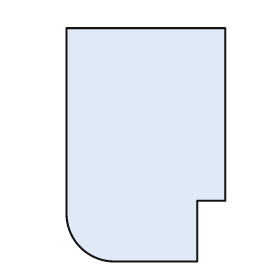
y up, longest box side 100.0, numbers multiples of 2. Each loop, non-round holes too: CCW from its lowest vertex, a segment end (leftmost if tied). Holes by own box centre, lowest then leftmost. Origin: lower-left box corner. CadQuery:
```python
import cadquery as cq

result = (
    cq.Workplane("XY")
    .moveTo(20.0, 0.0)
    .lineTo(56.0, 0.0)
    .lineTo(56.0, 26.0)
    .lineTo(68.0, 26.0)
    .lineTo(68.0, 100.0)
    .lineTo(0.0, 100.0)
    .lineTo(0.0, 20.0)
    .threePointArc((6.0, 6.0), (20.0, 0.0))
    .close()
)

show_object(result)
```